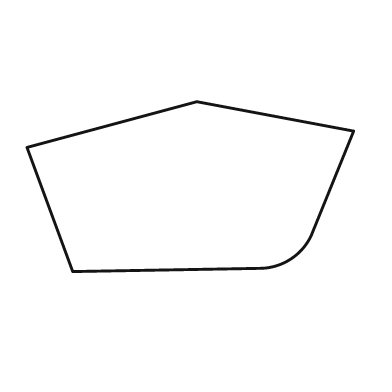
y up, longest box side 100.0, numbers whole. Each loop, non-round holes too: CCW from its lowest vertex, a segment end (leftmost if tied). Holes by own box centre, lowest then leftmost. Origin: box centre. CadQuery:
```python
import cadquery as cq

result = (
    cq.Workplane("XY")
    .moveTo(-36.0, -26.0)
    .lineTo(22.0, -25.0)
    .threePointArc((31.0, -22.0), (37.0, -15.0))
    .lineTo(50.0, 17.0)
    .lineTo(2.0, 26.0)
    .lineTo(-50.0, 12.0)
    .close()
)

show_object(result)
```